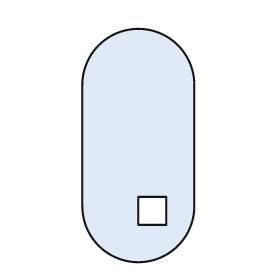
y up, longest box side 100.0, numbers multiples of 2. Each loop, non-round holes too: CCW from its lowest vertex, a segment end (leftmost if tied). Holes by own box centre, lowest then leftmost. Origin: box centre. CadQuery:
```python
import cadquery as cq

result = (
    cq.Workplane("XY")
    .moveTo(-24.0, -26.0)
    .threePointArc((0.0, -50.0), (24.0, -26.0))
    .lineTo(24.0, 26.0)
    .threePointArc((0.0, 50.0), (-24.0, 26.0))
    .close()
    .moveTo(0.0, -34.0)
    .lineTo(12.0, -34.0)
    .lineTo(12.0, -22.0)
    .lineTo(0.0, -22.0)
    .close()
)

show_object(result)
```